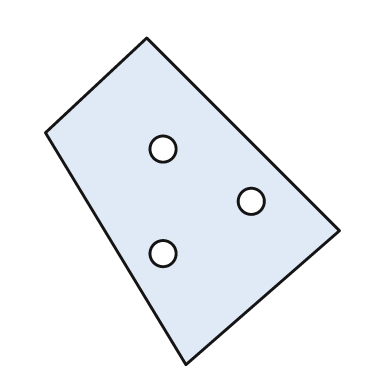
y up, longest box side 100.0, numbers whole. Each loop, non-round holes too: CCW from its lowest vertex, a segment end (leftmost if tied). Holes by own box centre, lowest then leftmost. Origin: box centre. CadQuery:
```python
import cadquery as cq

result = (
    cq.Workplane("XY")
    .moveTo(-2.0, -50.0)
    .lineTo(45.0, -9.0)
    .lineTo(-14.0, 50.0)
    .lineTo(-45.0, 21.0)
    .close()
    .moveTo(-9.0, -16.0)
    .circle(4.0)
    .moveTo(18.0, 0.0)
    .circle(4.0)
    .moveTo(-9.0, 16.0)
    .circle(4.0)
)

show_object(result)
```